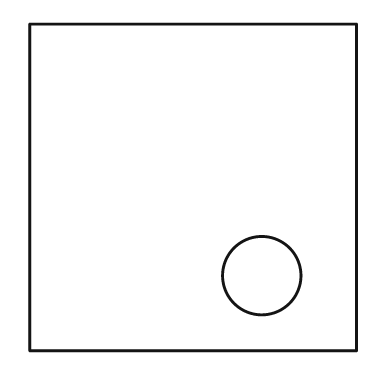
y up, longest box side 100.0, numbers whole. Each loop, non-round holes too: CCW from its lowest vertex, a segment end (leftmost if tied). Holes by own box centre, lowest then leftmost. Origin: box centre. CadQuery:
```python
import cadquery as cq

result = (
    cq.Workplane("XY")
    .moveTo(-50.0, -50.0)
    .lineTo(50.0, -50.0)
    .lineTo(50.0, 50.0)
    .lineTo(-50.0, 50.0)
    .close()
    .moveTo(21.0, -27.0)
    .circle(12.0)
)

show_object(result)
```